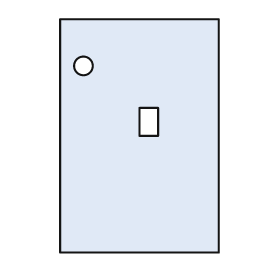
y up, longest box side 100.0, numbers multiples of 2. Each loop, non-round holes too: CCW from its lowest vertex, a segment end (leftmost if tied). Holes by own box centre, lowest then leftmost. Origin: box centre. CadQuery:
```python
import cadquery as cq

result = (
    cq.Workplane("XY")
    .moveTo(-34.0, -50.0)
    .lineTo(34.0, -50.0)
    .lineTo(34.0, 50.0)
    .lineTo(-34.0, 50.0)
    .close()
    .moveTo(0.0, 0.0)
    .lineTo(8.0, 0.0)
    .lineTo(8.0, 12.0)
    .lineTo(0.0, 12.0)
    .close()
    .moveTo(-24.0, 30.0)
    .circle(4.0)
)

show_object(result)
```